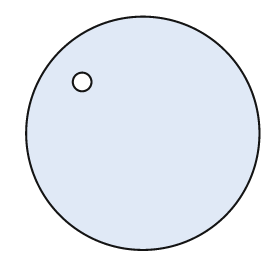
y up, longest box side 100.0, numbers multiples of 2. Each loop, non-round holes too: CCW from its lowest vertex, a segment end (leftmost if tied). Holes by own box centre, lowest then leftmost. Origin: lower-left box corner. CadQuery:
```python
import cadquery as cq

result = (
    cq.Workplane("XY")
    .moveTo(50.0, 50.0)
    .circle(50.0)
    .moveTo(24.0, 72.0)
    .circle(4.0)
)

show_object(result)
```